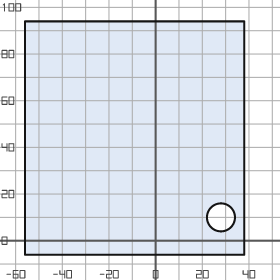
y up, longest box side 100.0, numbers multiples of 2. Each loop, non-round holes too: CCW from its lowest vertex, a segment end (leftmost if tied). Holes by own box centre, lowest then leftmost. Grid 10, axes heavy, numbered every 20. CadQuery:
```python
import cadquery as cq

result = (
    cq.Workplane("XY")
    .moveTo(-56.0, -6.0)
    .lineTo(38.0, -6.0)
    .lineTo(38.0, 94.0)
    .lineTo(-56.0, 94.0)
    .close()
    .moveTo(28.0, 10.0)
    .circle(6.0)
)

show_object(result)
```